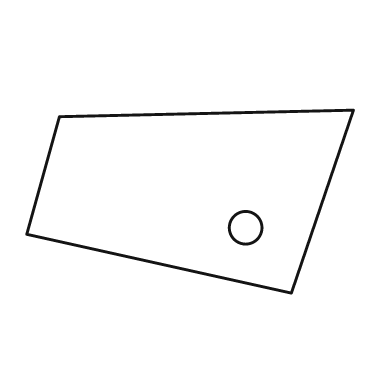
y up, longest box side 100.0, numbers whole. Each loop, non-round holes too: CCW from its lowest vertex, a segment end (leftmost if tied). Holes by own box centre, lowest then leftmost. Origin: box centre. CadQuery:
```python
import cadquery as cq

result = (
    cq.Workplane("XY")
    .moveTo(31.0, -28.0)
    .lineTo(50.0, 28.0)
    .lineTo(-40.0, 26.0)
    .lineTo(-50.0, -10.0)
    .close()
    .moveTo(17.0, -8.0)
    .circle(5.0)
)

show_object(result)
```